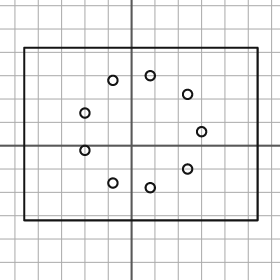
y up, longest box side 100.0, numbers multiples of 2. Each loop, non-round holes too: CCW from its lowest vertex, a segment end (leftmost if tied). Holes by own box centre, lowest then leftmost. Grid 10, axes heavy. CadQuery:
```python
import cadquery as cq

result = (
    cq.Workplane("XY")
    .moveTo(-46.0, -32.0)
    .lineTo(54.0, -32.0)
    .lineTo(54.0, 42.0)
    .lineTo(-46.0, 42.0)
    .close()
    .moveTo(8.0, -18.0)
    .circle(2.0)
    .moveTo(-8.0, -16.0)
    .circle(2.0)
    .moveTo(24.0, -10.0)
    .circle(2.0)
    .moveTo(-20.0, -2.0)
    .circle(2.0)
    .moveTo(30.0, 6.0)
    .circle(2.0)
    .moveTo(-20.0, 14.0)
    .circle(2.0)
    .moveTo(24.0, 22.0)
    .circle(2.0)
    .moveTo(-8.0, 28.0)
    .circle(2.0)
    .moveTo(8.0, 30.0)
    .circle(2.0)
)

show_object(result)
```